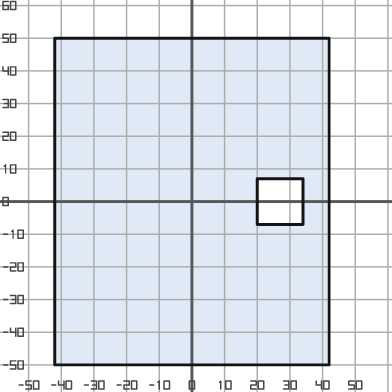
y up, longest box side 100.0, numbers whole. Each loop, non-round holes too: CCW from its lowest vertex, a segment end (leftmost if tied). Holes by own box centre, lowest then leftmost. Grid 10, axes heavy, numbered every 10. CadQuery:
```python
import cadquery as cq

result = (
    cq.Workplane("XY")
    .moveTo(-42.0, -50.0)
    .lineTo(42.0, -50.0)
    .lineTo(42.0, 50.0)
    .lineTo(-42.0, 50.0)
    .close()
    .moveTo(20.0, -7.0)
    .lineTo(34.0, -7.0)
    .lineTo(34.0, 7.0)
    .lineTo(20.0, 7.0)
    .close()
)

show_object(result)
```